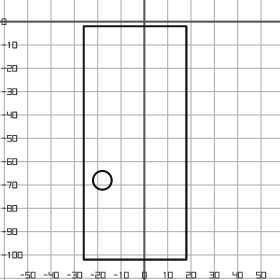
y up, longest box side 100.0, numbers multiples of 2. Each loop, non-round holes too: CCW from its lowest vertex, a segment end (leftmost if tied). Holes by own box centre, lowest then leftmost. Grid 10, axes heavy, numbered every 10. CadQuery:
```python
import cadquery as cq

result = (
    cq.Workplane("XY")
    .moveTo(-26.0, -102.0)
    .lineTo(18.0, -102.0)
    .lineTo(18.0, -2.0)
    .lineTo(-26.0, -2.0)
    .close()
    .moveTo(-18.0, -68.0)
    .circle(4.0)
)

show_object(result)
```